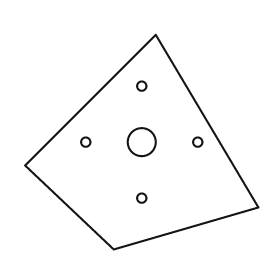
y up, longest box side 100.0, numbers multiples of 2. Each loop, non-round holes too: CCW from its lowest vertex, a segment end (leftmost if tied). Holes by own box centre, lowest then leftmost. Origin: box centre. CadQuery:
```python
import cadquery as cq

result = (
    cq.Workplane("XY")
    .moveTo(-12.0, -46.0)
    .lineTo(50.0, -28.0)
    .lineTo(6.0, 46.0)
    .lineTo(-50.0, -10.0)
    .close()
    .moveTo(0.0, -24.0)
    .circle(2.0)
    .moveTo(-24.0, 0.0)
    .circle(2.0)
    .moveTo(0.0, 0.0)
    .circle(6.0)
    .moveTo(24.0, 0.0)
    .circle(2.0)
    .moveTo(0.0, 24.0)
    .circle(2.0)
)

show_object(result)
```